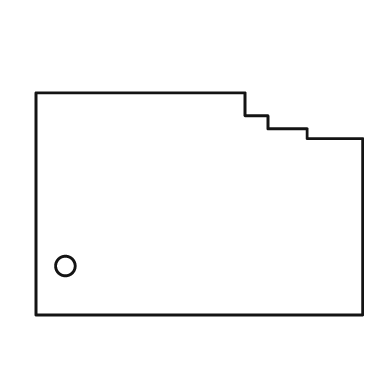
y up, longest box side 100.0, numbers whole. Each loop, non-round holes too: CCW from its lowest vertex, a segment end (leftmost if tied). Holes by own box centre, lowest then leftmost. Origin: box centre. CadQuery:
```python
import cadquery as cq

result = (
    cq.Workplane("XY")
    .moveTo(-50.0, -34.0)
    .lineTo(50.0, -34.0)
    .lineTo(50.0, 20.0)
    .lineTo(33.0, 20.0)
    .lineTo(33.0, 23.0)
    .lineTo(21.0, 23.0)
    .lineTo(21.0, 27.0)
    .lineTo(14.0, 27.0)
    .lineTo(14.0, 34.0)
    .lineTo(-50.0, 34.0)
    .close()
    .moveTo(-41.0, -19.0)
    .circle(3.0)
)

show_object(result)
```